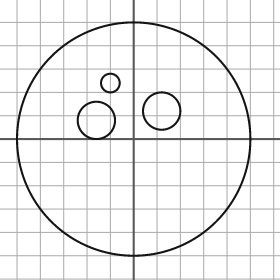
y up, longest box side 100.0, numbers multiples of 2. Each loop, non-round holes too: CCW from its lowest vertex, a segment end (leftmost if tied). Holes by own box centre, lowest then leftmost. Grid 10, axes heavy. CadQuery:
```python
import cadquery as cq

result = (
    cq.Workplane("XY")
    .moveTo(0.0, 0.0)
    .circle(50.0)
    .moveTo(-16.0, 8.0)
    .circle(8.0)
    .moveTo(12.0, 12.0)
    .circle(8.0)
    .moveTo(-10.0, 24.0)
    .circle(4.0)
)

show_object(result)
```